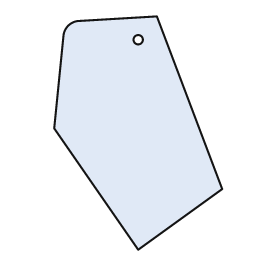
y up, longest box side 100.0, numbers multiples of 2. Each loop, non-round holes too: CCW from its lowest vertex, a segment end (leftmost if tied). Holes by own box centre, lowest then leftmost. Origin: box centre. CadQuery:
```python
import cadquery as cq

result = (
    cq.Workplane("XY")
    .moveTo(0.0, -50.0)
    .lineTo(36.0, -24.0)
    .lineTo(8.0, 50.0)
    .lineTo(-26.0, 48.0)
    .threePointArc((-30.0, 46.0), (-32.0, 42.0))
    .lineTo(-36.0, 2.0)
    .close()
    .moveTo(0.0, 40.0)
    .circle(2.0)
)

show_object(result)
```